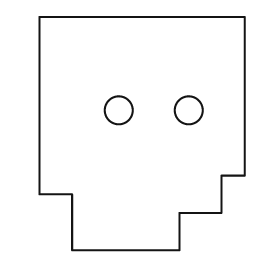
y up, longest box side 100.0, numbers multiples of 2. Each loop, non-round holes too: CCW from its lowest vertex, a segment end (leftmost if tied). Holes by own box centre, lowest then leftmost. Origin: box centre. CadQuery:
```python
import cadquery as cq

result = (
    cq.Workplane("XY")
    .moveTo(-30.0, -50.0)
    .lineTo(16.0, -50.0)
    .lineTo(16.0, -34.0)
    .lineTo(34.0, -34.0)
    .lineTo(34.0, -18.0)
    .lineTo(44.0, -18.0)
    .lineTo(44.0, 50.0)
    .lineTo(-44.0, 50.0)
    .lineTo(-44.0, -26.0)
    .lineTo(-30.0, -26.0)
    .close()
    .moveTo(-10.0, 10.0)
    .circle(6.0)
    .moveTo(20.0, 10.0)
    .circle(6.0)
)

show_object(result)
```